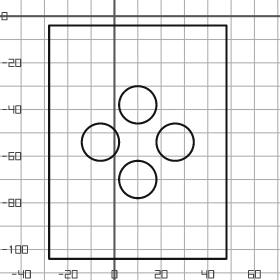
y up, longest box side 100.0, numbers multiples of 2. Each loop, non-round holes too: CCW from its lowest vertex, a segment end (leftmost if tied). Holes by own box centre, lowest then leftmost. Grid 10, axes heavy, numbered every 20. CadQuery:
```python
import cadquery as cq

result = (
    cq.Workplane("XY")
    .moveTo(-28.0, -104.0)
    .lineTo(48.0, -104.0)
    .lineTo(48.0, -4.0)
    .lineTo(-28.0, -4.0)
    .close()
    .moveTo(10.0, -70.0)
    .circle(8.0)
    .moveTo(-6.0, -54.0)
    .circle(8.0)
    .moveTo(26.0, -54.0)
    .circle(8.0)
    .moveTo(10.0, -38.0)
    .circle(8.0)
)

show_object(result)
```